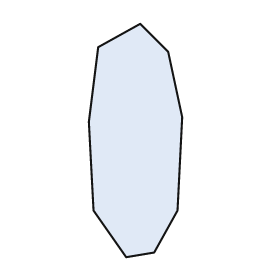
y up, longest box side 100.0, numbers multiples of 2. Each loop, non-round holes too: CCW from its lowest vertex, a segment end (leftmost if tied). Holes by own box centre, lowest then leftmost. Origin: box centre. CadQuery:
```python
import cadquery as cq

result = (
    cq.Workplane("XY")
    .moveTo(-4.0, -50.0)
    .lineTo(8.0, -48.0)
    .lineTo(18.0, -30.0)
    .lineTo(20.0, 10.0)
    .lineTo(14.0, 38.0)
    .lineTo(2.0, 50.0)
    .lineTo(-16.0, 40.0)
    .lineTo(-20.0, 8.0)
    .lineTo(-18.0, -30.0)
    .close()
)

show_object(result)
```